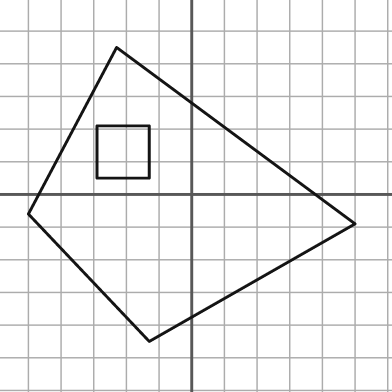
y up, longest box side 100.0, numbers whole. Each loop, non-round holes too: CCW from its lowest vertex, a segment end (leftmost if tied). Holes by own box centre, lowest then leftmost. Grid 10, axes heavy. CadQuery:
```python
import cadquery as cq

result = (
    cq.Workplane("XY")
    .moveTo(-13.0, -45.0)
    .lineTo(50.0, -9.0)
    .lineTo(-23.0, 45.0)
    .lineTo(-50.0, -6.0)
    .close()
    .moveTo(-29.0, 5.0)
    .lineTo(-13.0, 5.0)
    .lineTo(-13.0, 21.0)
    .lineTo(-29.0, 21.0)
    .close()
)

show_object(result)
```